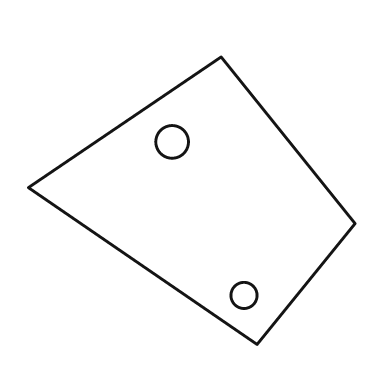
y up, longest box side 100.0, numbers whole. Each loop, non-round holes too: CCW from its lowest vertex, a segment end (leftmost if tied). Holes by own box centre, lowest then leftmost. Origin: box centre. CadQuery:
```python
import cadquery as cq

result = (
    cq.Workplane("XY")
    .moveTo(20.0, -44.0)
    .lineTo(50.0, -7.0)
    .lineTo(9.0, 44.0)
    .lineTo(-50.0, 4.0)
    .close()
    .moveTo(16.0, -29.0)
    .circle(4.0)
    .moveTo(-6.0, 18.0)
    .circle(5.0)
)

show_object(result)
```